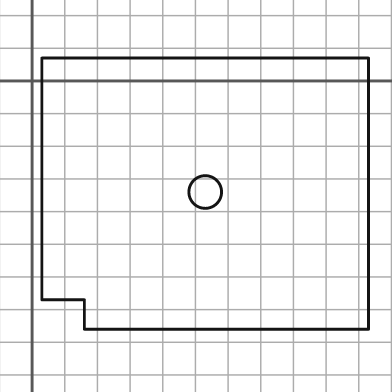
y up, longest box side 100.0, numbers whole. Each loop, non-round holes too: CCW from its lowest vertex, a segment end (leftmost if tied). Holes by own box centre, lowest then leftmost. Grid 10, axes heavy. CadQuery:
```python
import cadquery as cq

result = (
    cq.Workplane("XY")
    .moveTo(16.0, -76.0)
    .lineTo(103.0, -76.0)
    .lineTo(103.0, 7.0)
    .lineTo(3.0, 7.0)
    .lineTo(3.0, -67.0)
    .lineTo(16.0, -67.0)
    .close()
    .moveTo(53.0, -34.0)
    .circle(5.0)
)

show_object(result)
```